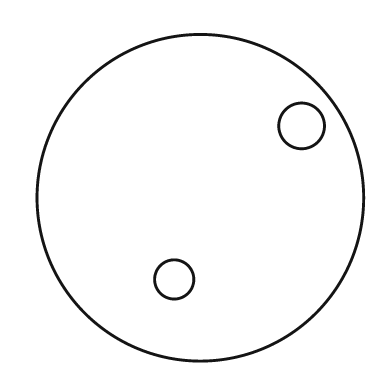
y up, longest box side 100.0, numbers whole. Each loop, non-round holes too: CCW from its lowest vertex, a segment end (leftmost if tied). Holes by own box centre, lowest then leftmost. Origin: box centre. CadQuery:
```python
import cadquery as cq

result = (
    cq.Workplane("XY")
    .moveTo(0.0, 0.0)
    .circle(50.0)
    .moveTo(-8.0, -25.0)
    .circle(6.0)
    .moveTo(31.0, 22.0)
    .circle(7.0)
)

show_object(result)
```